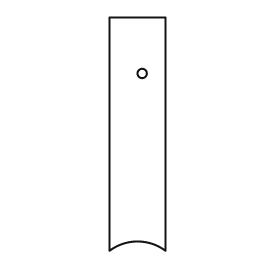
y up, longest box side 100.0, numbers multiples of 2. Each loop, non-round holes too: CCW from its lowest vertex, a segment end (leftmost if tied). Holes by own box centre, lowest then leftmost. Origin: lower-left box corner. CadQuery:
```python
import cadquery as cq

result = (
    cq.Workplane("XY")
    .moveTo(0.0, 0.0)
    .threePointArc((12.0, 4.0), (24.0, 0.0))
    .lineTo(24.0, 100.0)
    .lineTo(0.0, 100.0)
    .close()
    .moveTo(14.0, 76.0)
    .circle(2.0)
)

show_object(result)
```